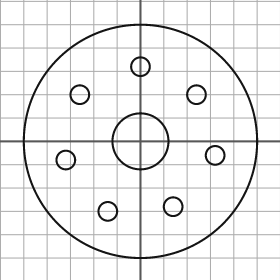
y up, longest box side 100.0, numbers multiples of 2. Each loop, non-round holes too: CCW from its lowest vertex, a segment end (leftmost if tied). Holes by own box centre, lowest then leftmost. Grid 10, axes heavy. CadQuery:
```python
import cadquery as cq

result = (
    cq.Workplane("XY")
    .moveTo(0.0, 0.0)
    .circle(50.0)
    .moveTo(-14.0, -30.0)
    .circle(4.0)
    .moveTo(14.0, -28.0)
    .circle(4.0)
    .moveTo(-32.0, -8.0)
    .circle(4.0)
    .moveTo(32.0, -6.0)
    .circle(4.0)
    .moveTo(0.0, 0.0)
    .circle(12.0)
    .moveTo(-26.0, 20.0)
    .circle(4.0)
    .moveTo(24.0, 20.0)
    .circle(4.0)
    .moveTo(0.0, 32.0)
    .circle(4.0)
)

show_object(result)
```